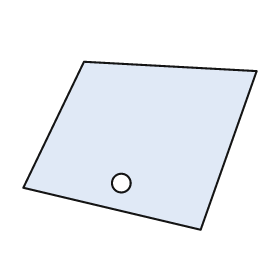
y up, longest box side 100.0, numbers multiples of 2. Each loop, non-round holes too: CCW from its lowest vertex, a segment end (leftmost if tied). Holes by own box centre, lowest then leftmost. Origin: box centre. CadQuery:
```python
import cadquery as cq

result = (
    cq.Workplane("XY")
    .moveTo(26.0, -36.0)
    .lineTo(50.0, 32.0)
    .lineTo(-24.0, 36.0)
    .lineTo(-50.0, -18.0)
    .close()
    .moveTo(-8.0, -16.0)
    .circle(4.0)
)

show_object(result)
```